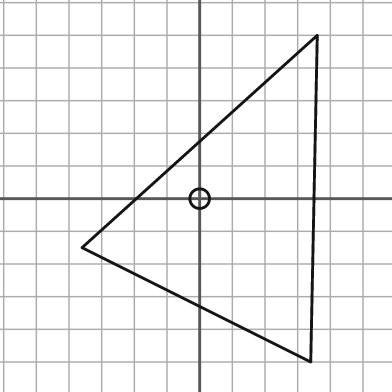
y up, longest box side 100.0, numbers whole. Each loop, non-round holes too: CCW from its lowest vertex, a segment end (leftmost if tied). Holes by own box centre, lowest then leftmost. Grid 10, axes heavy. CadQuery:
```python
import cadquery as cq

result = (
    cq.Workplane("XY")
    .moveTo(34.0, -50.0)
    .lineTo(36.0, 50.0)
    .lineTo(-36.0, -15.0)
    .close()
    .moveTo(0.0, 0.0)
    .circle(3.0)
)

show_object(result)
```